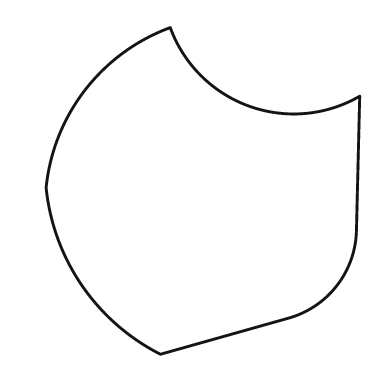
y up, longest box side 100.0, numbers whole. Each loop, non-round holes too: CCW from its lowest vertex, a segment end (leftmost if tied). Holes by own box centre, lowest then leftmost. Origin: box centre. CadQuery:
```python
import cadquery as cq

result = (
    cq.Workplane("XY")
    .moveTo(-13.0, -50.0)
    .lineTo(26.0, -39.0)
    .threePointArc((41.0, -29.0), (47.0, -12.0))
    .lineTo(48.0, 29.0)
    .threePointArc((14.0, 26.0), (-10.0, 50.0))
    .threePointArc((-36.0, 31.0), (-48.0, 1.0))
    .threePointArc((-37.0, -29.0), (-13.0, -50.0))
    .close()
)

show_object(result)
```